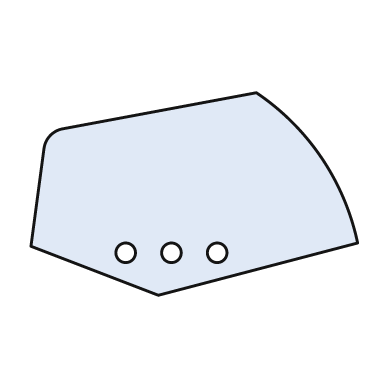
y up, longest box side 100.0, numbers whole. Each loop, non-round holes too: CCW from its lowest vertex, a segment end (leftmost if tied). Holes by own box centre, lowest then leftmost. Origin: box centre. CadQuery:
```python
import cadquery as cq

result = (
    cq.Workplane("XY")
    .moveTo(-11.0, -31.0)
    .lineTo(50.0, -15.0)
    .threePointArc((39.0, 11.0), (19.0, 31.0))
    .lineTo(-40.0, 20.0)
    .threePointArc((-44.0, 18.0), (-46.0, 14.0))
    .lineTo(-50.0, -16.0)
    .close()
    .moveTo(-21.0, -18.0)
    .circle(3.0)
    .moveTo(-7.0, -18.0)
    .circle(3.0)
    .moveTo(7.0, -18.0)
    .circle(3.0)
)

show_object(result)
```